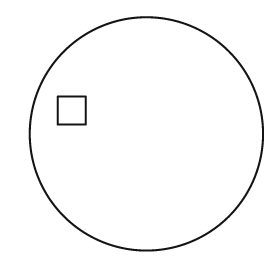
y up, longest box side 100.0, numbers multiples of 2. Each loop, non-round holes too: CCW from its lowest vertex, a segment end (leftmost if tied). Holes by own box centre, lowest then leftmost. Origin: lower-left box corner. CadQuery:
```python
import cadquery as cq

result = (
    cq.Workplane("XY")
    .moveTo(50.0, 50.0)
    .circle(50.0)
    .moveTo(12.0, 54.0)
    .lineTo(24.0, 54.0)
    .lineTo(24.0, 66.0)
    .lineTo(12.0, 66.0)
    .close()
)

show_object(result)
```